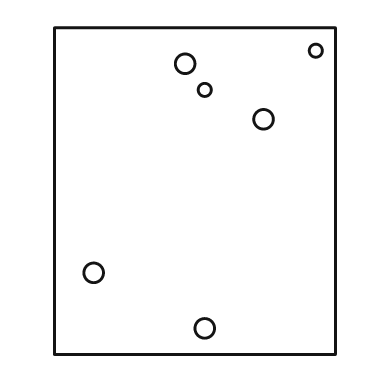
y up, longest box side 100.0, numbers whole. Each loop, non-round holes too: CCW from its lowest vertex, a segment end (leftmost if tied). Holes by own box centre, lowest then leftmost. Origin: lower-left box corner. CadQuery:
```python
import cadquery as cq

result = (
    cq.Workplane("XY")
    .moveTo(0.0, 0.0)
    .lineTo(86.0, 0.0)
    .lineTo(86.0, 100.0)
    .lineTo(0.0, 100.0)
    .close()
    .moveTo(46.0, 8.0)
    .circle(3.0)
    .moveTo(12.0, 25.0)
    .circle(3.0)
    .moveTo(64.0, 72.0)
    .circle(3.0)
    .moveTo(46.0, 81.0)
    .circle(2.0)
    .moveTo(40.0, 89.0)
    .circle(3.0)
    .moveTo(80.0, 93.0)
    .circle(2.0)
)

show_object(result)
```